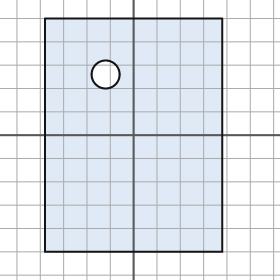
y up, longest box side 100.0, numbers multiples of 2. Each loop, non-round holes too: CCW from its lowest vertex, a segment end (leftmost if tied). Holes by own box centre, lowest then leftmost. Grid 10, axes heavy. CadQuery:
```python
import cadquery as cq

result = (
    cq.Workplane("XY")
    .moveTo(-38.0, -50.0)
    .lineTo(38.0, -50.0)
    .lineTo(38.0, 50.0)
    .lineTo(-38.0, 50.0)
    .close()
    .moveTo(-12.0, 26.0)
    .circle(6.0)
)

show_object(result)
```